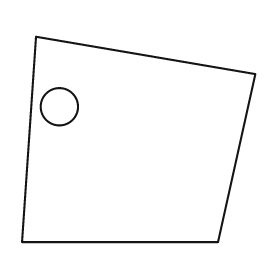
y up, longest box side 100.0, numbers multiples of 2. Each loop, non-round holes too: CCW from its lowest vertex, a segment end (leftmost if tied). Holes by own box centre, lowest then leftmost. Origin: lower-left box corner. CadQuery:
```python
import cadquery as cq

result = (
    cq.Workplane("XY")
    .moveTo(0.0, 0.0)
    .lineTo(84.0, 0.0)
    .lineTo(100.0, 72.0)
    .lineTo(6.0, 88.0)
    .close()
    .moveTo(16.0, 58.0)
    .circle(8.0)
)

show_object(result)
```